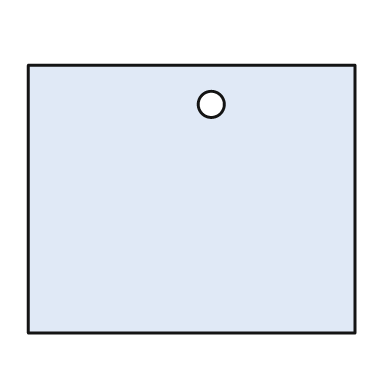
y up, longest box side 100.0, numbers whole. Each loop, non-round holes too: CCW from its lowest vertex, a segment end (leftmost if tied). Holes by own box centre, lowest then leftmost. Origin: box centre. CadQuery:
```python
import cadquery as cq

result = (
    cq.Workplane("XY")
    .moveTo(-50.0, -41.0)
    .lineTo(50.0, -41.0)
    .lineTo(50.0, 41.0)
    .lineTo(-50.0, 41.0)
    .close()
    .moveTo(6.0, 29.0)
    .circle(4.0)
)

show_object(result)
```